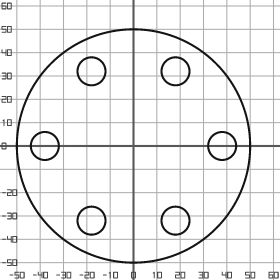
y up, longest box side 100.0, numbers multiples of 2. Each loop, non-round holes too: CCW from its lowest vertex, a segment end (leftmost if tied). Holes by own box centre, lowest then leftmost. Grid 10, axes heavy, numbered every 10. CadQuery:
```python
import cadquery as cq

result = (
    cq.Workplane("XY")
    .moveTo(0.0, 0.0)
    .circle(50.0)
    .moveTo(-18.0, -32.0)
    .circle(6.0)
    .moveTo(18.0, -32.0)
    .circle(6.0)
    .moveTo(-38.0, 0.0)
    .circle(6.0)
    .moveTo(38.0, 0.0)
    .circle(6.0)
    .moveTo(-18.0, 32.0)
    .circle(6.0)
    .moveTo(18.0, 32.0)
    .circle(6.0)
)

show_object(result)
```